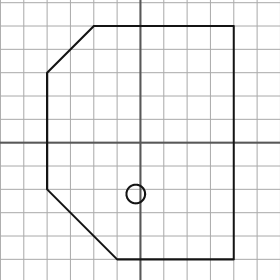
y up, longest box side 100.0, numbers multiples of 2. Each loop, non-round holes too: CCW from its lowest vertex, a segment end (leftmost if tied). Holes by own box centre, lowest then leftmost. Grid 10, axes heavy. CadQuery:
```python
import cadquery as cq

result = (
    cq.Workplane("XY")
    .moveTo(-10.0, -50.0)
    .lineTo(40.0, -50.0)
    .lineTo(40.0, 50.0)
    .lineTo(-20.0, 50.0)
    .lineTo(-40.0, 30.0)
    .lineTo(-40.0, -20.0)
    .close()
    .moveTo(-2.0, -22.0)
    .circle(4.0)
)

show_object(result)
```